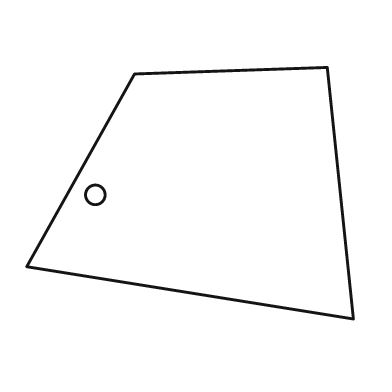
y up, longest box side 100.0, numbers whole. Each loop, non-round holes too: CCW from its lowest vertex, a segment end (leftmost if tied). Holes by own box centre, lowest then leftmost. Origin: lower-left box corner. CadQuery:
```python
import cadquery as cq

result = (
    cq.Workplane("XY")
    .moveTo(100.0, 0.0)
    .lineTo(92.0, 77.0)
    .lineTo(33.0, 75.0)
    .lineTo(0.0, 16.0)
    .close()
    .moveTo(21.0, 38.0)
    .circle(3.0)
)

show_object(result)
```